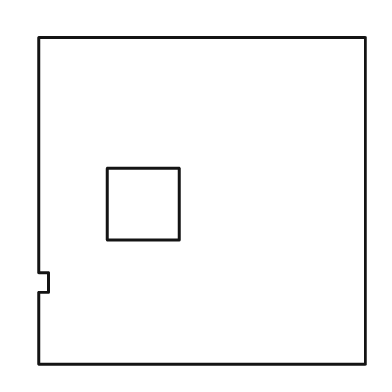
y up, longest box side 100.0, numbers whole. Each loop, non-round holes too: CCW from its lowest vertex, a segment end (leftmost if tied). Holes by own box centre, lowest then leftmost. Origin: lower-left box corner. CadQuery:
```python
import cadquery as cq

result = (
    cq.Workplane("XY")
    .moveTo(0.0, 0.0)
    .lineTo(100.0, 0.0)
    .lineTo(100.0, 100.0)
    .lineTo(0.0, 100.0)
    .lineTo(0.0, 28.0)
    .lineTo(3.0, 28.0)
    .lineTo(3.0, 22.0)
    .lineTo(0.0, 22.0)
    .close()
    .moveTo(21.0, 38.0)
    .lineTo(43.0, 38.0)
    .lineTo(43.0, 60.0)
    .lineTo(21.0, 60.0)
    .close()
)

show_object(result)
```